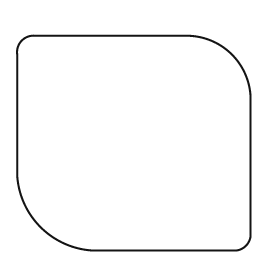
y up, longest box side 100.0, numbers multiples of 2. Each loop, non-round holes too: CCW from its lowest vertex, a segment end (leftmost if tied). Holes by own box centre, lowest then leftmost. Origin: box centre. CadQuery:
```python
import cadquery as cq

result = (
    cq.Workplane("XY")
    .moveTo(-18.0, -46.0)
    .lineTo(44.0, -46.0)
    .threePointArc((48.0, -44.0), (50.0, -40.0))
    .lineTo(50.0, 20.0)
    .threePointArc((42.0, 38.0), (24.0, 46.0))
    .lineTo(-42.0, 46.0)
    .threePointArc((-48.0, 44.0), (-50.0, 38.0))
    .lineTo(-50.0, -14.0)
    .threePointArc((-40.0, -36.0), (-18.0, -46.0))
    .close()
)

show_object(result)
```